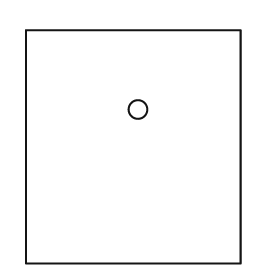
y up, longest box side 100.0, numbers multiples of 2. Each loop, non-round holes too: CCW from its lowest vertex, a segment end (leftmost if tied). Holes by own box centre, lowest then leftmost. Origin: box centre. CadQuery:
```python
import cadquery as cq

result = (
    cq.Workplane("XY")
    .moveTo(-46.0, -50.0)
    .lineTo(46.0, -50.0)
    .lineTo(46.0, 50.0)
    .lineTo(-46.0, 50.0)
    .close()
    .moveTo(2.0, 16.0)
    .circle(4.0)
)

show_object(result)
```